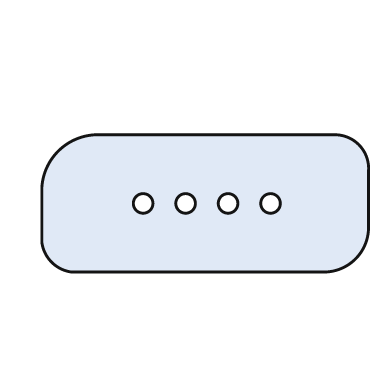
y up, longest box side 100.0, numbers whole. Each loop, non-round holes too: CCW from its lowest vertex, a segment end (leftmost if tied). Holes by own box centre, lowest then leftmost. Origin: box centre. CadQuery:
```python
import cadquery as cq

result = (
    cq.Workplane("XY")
    .moveTo(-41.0, -21.0)
    .lineTo(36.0, -21.0)
    .threePointArc((46.0, -17.0), (50.0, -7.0))
    .lineTo(50.0, 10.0)
    .threePointArc((47.0, 18.0), (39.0, 21.0))
    .lineTo(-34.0, 21.0)
    .threePointArc((-45.0, 16.0), (-50.0, 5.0))
    .lineTo(-50.0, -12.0)
    .threePointArc((-47.0, -18.0), (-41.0, -21.0))
    .close()
    .moveTo(-19.0, 0.0)
    .circle(3.0)
    .moveTo(-6.0, 0.0)
    .circle(3.0)
    .moveTo(7.0, 0.0)
    .circle(3.0)
    .moveTo(20.0, 0.0)
    .circle(3.0)
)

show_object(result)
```